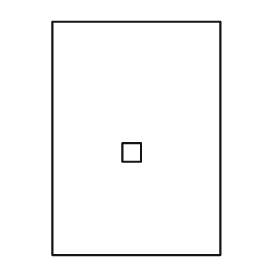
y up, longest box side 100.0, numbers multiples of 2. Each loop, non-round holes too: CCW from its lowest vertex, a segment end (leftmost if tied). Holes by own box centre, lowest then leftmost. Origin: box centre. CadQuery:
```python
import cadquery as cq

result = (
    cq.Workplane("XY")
    .moveTo(-36.0, -50.0)
    .lineTo(36.0, -50.0)
    .lineTo(36.0, 50.0)
    .lineTo(-36.0, 50.0)
    .close()
    .moveTo(-6.0, -10.0)
    .lineTo(2.0, -10.0)
    .lineTo(2.0, -2.0)
    .lineTo(-6.0, -2.0)
    .close()
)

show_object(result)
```